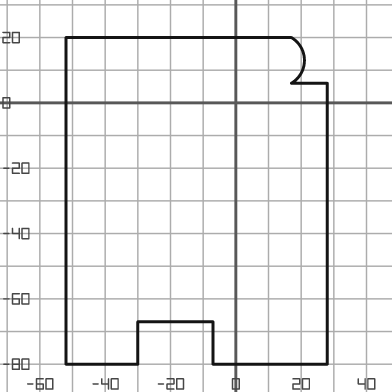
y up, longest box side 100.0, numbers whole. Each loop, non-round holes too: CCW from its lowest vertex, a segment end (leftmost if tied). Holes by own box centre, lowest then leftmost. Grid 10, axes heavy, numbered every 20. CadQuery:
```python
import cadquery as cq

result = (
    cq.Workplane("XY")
    .moveTo(-52.0, -80.0)
    .lineTo(-30.0, -80.0)
    .lineTo(-30.0, -67.0)
    .lineTo(-7.0, -67.0)
    .lineTo(-7.0, -80.0)
    .lineTo(28.0, -80.0)
    .lineTo(28.0, 6.0)
    .lineTo(17.0, 6.0)
    .threePointArc((21.0, 13.0), (17.0, 20.0))
    .lineTo(-52.0, 20.0)
    .close()
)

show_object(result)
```